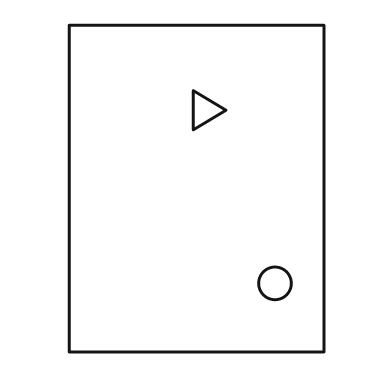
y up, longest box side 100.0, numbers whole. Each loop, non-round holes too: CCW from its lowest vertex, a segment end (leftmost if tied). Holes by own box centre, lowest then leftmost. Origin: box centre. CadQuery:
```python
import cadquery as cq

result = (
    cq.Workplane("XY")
    .moveTo(-39.0, -50.0)
    .lineTo(39.0, -50.0)
    .lineTo(39.0, 50.0)
    .lineTo(-39.0, 50.0)
    .close()
    .moveTo(24.0, -29.0)
    .circle(5.0)
    .moveTo(-1.0, 18.0)
    .lineTo(9.0, 24.0)
    .lineTo(-1.0, 30.0)
    .close()
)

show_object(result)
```